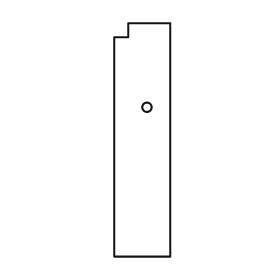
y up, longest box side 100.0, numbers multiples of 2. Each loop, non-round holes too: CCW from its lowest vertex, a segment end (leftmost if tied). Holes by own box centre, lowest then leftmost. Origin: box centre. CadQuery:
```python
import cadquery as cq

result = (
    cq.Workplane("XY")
    .moveTo(-12.0, -50.0)
    .lineTo(12.0, -50.0)
    .lineTo(12.0, 50.0)
    .lineTo(-6.0, 50.0)
    .lineTo(-6.0, 44.0)
    .lineTo(-12.0, 44.0)
    .close()
    .moveTo(2.0, 14.0)
    .circle(2.0)
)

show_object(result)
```